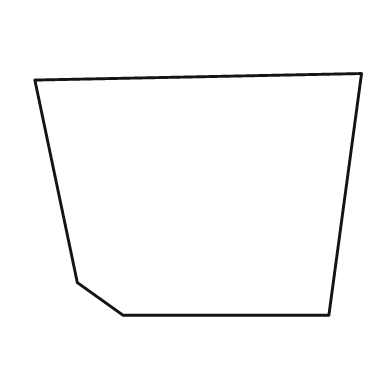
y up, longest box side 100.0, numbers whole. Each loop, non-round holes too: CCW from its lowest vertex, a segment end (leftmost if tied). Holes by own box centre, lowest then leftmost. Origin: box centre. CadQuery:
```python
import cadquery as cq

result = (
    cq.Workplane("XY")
    .moveTo(-23.0, -37.0)
    .lineTo(40.0, -37.0)
    .lineTo(50.0, 37.0)
    .lineTo(-50.0, 35.0)
    .lineTo(-37.0, -27.0)
    .close()
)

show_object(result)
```